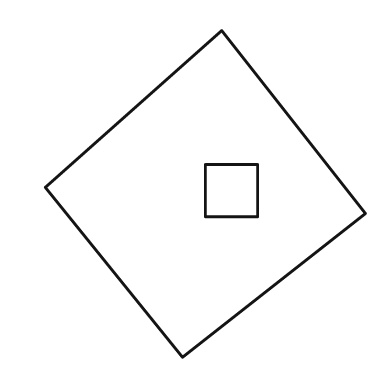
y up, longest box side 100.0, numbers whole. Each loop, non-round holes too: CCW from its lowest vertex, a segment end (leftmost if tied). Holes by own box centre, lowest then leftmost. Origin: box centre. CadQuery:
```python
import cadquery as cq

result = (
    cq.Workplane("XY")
    .moveTo(-7.0, -50.0)
    .lineTo(49.0, -6.0)
    .lineTo(5.0, 50.0)
    .lineTo(-49.0, 2.0)
    .close()
    .moveTo(0.0, -7.0)
    .lineTo(16.0, -7.0)
    .lineTo(16.0, 9.0)
    .lineTo(0.0, 9.0)
    .close()
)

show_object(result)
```